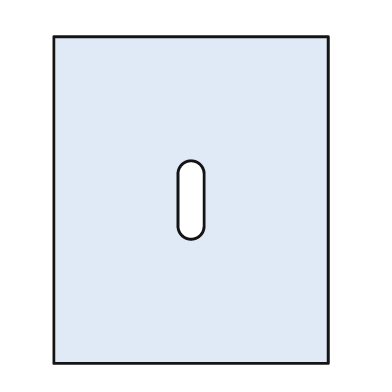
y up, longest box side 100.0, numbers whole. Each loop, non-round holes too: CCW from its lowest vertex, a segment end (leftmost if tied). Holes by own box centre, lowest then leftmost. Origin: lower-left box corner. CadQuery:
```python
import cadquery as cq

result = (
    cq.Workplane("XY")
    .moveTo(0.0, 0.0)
    .lineTo(84.0, 0.0)
    .lineTo(84.0, 100.0)
    .lineTo(0.0, 100.0)
    .close()
    .moveTo(38.0, 42.0)
    .threePointArc((42.0, 38.0), (46.0, 42.0))
    .lineTo(46.0, 58.0)
    .threePointArc((42.0, 62.0), (38.0, 58.0))
    .close()
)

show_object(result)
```